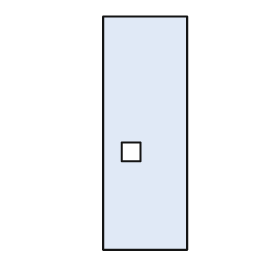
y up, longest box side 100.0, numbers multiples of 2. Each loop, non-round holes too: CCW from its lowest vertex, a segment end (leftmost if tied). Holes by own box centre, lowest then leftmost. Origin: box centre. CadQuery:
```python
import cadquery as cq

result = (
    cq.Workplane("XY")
    .moveTo(-18.0, -50.0)
    .lineTo(18.0, -50.0)
    .lineTo(18.0, 50.0)
    .lineTo(-18.0, 50.0)
    .close()
    .moveTo(-10.0, -12.0)
    .lineTo(-2.0, -12.0)
    .lineTo(-2.0, -4.0)
    .lineTo(-10.0, -4.0)
    .close()
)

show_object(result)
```